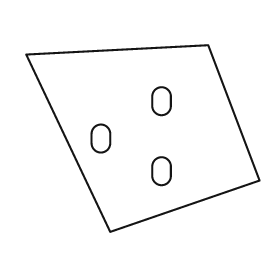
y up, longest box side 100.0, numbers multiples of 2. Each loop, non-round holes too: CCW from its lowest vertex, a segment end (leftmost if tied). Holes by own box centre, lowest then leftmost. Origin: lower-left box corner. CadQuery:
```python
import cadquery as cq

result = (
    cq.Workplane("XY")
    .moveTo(36.0, 0.0)
    .lineTo(100.0, 22.0)
    .lineTo(78.0, 80.0)
    .lineTo(0.0, 76.0)
    .close()
    .moveTo(54.0, 24.0)
    .threePointArc((58.0, 20.0), (62.0, 24.0))
    .lineTo(62.0, 28.0)
    .threePointArc((58.0, 32.0), (54.0, 28.0))
    .close()
    .moveTo(28.0, 38.0)
    .threePointArc((32.0, 34.0), (36.0, 38.0))
    .lineTo(36.0, 42.0)
    .threePointArc((32.0, 46.0), (28.0, 42.0))
    .close()
    .moveTo(54.0, 54.0)
    .threePointArc((58.0, 50.0), (62.0, 54.0))
    .lineTo(62.0, 58.0)
    .threePointArc((58.0, 62.0), (54.0, 58.0))
    .close()
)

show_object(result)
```